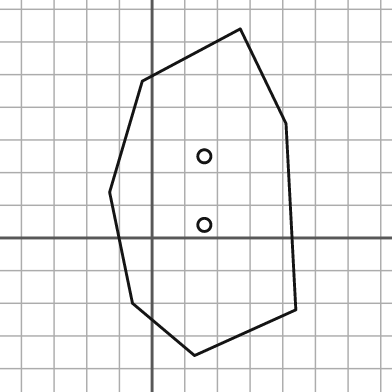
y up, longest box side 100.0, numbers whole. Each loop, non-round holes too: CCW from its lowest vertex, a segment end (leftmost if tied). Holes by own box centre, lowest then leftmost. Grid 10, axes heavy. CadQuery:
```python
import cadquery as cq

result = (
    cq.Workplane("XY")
    .moveTo(13.0, -36.0)
    .lineTo(44.0, -22.0)
    .lineTo(41.0, 35.0)
    .lineTo(27.0, 64.0)
    .lineTo(-3.0, 48.0)
    .lineTo(-13.0, 14.0)
    .lineTo(-6.0, -20.0)
    .close()
    .moveTo(16.0, 4.0)
    .circle(2.0)
    .moveTo(16.0, 25.0)
    .circle(2.0)
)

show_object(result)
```